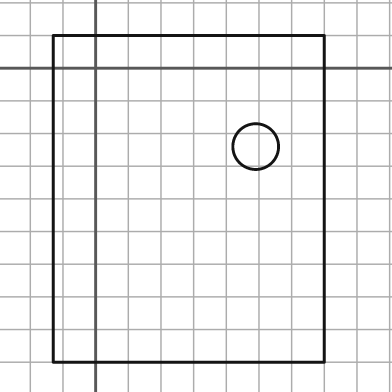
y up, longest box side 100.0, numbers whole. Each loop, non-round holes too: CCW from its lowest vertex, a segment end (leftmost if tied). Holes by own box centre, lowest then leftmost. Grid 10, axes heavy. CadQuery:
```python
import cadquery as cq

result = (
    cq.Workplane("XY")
    .moveTo(-13.0, -90.0)
    .lineTo(70.0, -90.0)
    .lineTo(70.0, 10.0)
    .lineTo(-13.0, 10.0)
    .close()
    .moveTo(49.0, -24.0)
    .circle(7.0)
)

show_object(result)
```